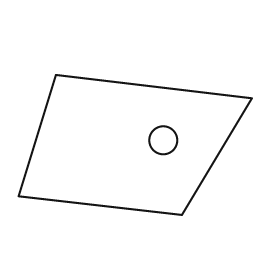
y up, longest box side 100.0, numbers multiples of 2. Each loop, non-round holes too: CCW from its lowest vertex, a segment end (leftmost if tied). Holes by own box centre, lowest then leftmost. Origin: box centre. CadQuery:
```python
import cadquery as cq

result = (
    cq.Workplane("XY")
    .moveTo(20.0, -30.0)
    .lineTo(50.0, 20.0)
    .lineTo(-34.0, 30.0)
    .lineTo(-50.0, -22.0)
    .close()
    .moveTo(12.0, 2.0)
    .circle(6.0)
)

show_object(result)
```